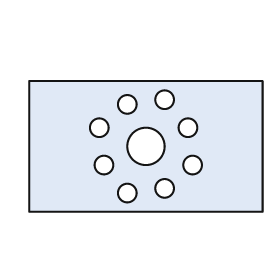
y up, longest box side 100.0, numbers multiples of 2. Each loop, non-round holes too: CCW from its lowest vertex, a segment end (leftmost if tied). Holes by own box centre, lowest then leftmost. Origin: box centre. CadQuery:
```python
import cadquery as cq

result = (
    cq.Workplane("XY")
    .moveTo(-50.0, -28.0)
    .lineTo(50.0, -28.0)
    .lineTo(50.0, 28.0)
    .lineTo(-50.0, 28.0)
    .close()
    .moveTo(-8.0, -20.0)
    .circle(4.0)
    .moveTo(8.0, -18.0)
    .circle(4.0)
    .moveTo(-18.0, -8.0)
    .circle(4.0)
    .moveTo(20.0, -8.0)
    .circle(4.0)
    .moveTo(0.0, 0.0)
    .circle(8.0)
    .moveTo(-20.0, 8.0)
    .circle(4.0)
    .moveTo(18.0, 8.0)
    .circle(4.0)
    .moveTo(-8.0, 18.0)
    .circle(4.0)
    .moveTo(8.0, 20.0)
    .circle(4.0)
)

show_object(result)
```